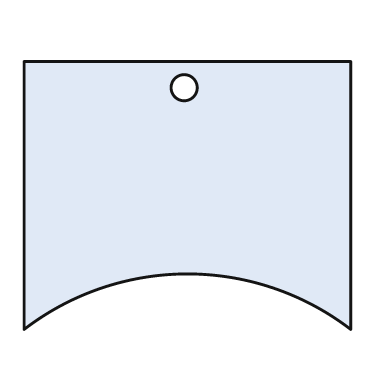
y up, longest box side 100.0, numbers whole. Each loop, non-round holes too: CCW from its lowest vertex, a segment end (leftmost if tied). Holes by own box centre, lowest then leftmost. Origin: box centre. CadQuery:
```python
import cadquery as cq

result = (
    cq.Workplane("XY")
    .moveTo(-50.0, -41.0)
    .threePointArc((0.0, -24.0), (50.0, -41.0))
    .lineTo(50.0, 41.0)
    .lineTo(-50.0, 41.0)
    .close()
    .moveTo(-1.0, 33.0)
    .circle(4.0)
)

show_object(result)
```